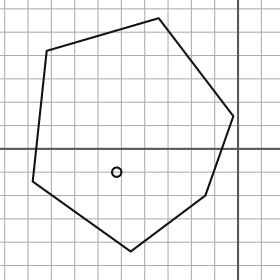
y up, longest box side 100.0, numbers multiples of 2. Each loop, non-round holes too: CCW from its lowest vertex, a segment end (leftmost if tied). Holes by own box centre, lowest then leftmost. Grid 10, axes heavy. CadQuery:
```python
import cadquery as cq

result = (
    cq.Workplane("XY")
    .moveTo(-46.0, -44.0)
    .lineTo(-14.0, -20.0)
    .lineTo(-2.0, 14.0)
    .lineTo(-34.0, 56.0)
    .lineTo(-82.0, 42.0)
    .lineTo(-88.0, -14.0)
    .close()
    .moveTo(-52.0, -10.0)
    .circle(2.0)
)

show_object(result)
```